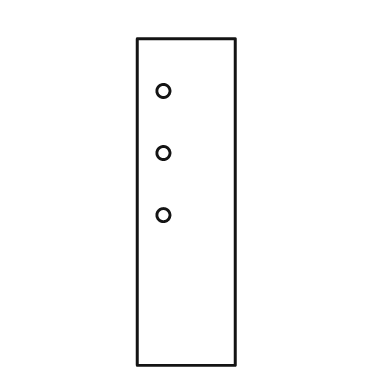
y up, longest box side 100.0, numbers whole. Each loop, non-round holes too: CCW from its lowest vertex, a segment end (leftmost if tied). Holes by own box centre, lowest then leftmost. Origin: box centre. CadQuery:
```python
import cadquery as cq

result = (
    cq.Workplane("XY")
    .moveTo(-15.0, -50.0)
    .lineTo(15.0, -50.0)
    .lineTo(15.0, 50.0)
    .lineTo(-15.0, 50.0)
    .close()
    .moveTo(-7.0, -4.0)
    .circle(2.0)
    .moveTo(-7.0, 15.0)
    .circle(2.0)
    .moveTo(-7.0, 34.0)
    .circle(2.0)
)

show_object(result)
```